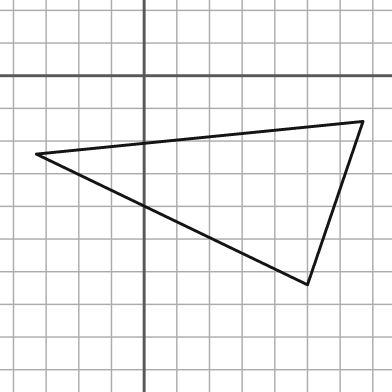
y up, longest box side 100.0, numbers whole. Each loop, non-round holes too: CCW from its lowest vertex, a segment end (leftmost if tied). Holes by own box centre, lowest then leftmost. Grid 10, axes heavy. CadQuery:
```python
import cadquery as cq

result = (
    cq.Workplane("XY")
    .moveTo(50.0, -64.0)
    .lineTo(67.0, -14.0)
    .lineTo(-33.0, -24.0)
    .close()
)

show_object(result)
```